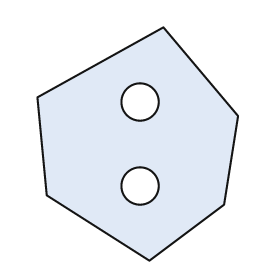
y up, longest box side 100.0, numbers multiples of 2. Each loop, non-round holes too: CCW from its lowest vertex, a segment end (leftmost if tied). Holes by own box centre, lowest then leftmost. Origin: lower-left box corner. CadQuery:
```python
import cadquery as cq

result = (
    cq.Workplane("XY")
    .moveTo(48.0, 0.0)
    .lineTo(80.0, 24.0)
    .lineTo(86.0, 62.0)
    .lineTo(54.0, 100.0)
    .lineTo(0.0, 70.0)
    .lineTo(4.0, 28.0)
    .close()
    .moveTo(44.0, 32.0)
    .circle(8.0)
    .moveTo(44.0, 68.0)
    .circle(8.0)
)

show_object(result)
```